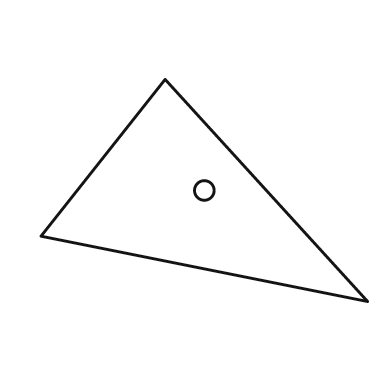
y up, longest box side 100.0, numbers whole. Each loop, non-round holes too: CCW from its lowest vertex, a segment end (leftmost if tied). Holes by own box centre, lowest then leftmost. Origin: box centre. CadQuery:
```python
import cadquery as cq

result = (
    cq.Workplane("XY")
    .moveTo(50.0, -34.0)
    .lineTo(-12.0, 34.0)
    .lineTo(-50.0, -14.0)
    .close()
    .moveTo(0.0, 0.0)
    .circle(3.0)
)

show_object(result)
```